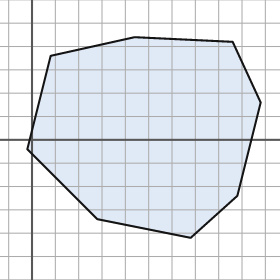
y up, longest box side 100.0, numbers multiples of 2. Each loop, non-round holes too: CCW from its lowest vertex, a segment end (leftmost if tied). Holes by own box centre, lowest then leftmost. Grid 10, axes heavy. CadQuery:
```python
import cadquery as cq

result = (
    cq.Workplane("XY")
    .moveTo(68.0, -42.0)
    .lineTo(88.0, -24.0)
    .lineTo(98.0, 16.0)
    .lineTo(86.0, 42.0)
    .lineTo(44.0, 44.0)
    .lineTo(8.0, 36.0)
    .lineTo(-2.0, -4.0)
    .lineTo(28.0, -34.0)
    .close()
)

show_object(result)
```